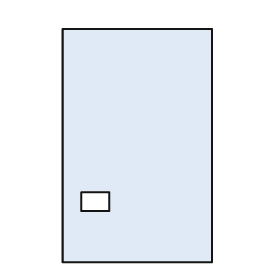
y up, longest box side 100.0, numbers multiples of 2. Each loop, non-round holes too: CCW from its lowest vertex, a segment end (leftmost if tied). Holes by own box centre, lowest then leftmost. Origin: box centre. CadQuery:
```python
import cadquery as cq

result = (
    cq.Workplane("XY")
    .moveTo(-32.0, -50.0)
    .lineTo(32.0, -50.0)
    .lineTo(32.0, 50.0)
    .lineTo(-32.0, 50.0)
    .close()
    .moveTo(-24.0, -28.0)
    .lineTo(-12.0, -28.0)
    .lineTo(-12.0, -20.0)
    .lineTo(-24.0, -20.0)
    .close()
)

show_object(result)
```